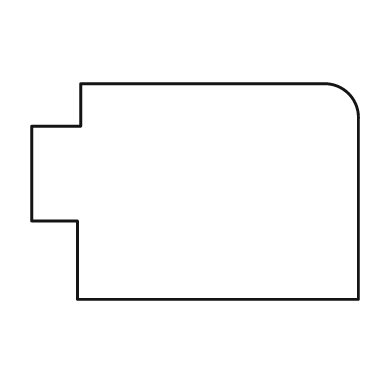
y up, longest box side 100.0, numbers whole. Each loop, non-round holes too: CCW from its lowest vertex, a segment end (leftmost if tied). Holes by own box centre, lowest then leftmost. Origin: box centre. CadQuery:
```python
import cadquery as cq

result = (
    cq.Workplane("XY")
    .moveTo(-36.0, -33.0)
    .lineTo(50.0, -33.0)
    .lineTo(50.0, 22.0)
    .threePointArc((47.0, 30.0), (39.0, 33.0))
    .lineTo(-35.0, 33.0)
    .lineTo(-35.0, 20.0)
    .lineTo(-50.0, 20.0)
    .lineTo(-50.0, -9.0)
    .lineTo(-36.0, -9.0)
    .close()
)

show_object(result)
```